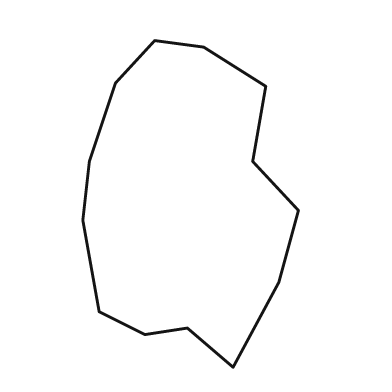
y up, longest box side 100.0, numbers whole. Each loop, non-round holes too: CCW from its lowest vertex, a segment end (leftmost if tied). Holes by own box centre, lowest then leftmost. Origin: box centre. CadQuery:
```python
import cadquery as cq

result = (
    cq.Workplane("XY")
    .moveTo(13.0, -50.0)
    .lineTo(27.0, -24.0)
    .lineTo(33.0, -2.0)
    .lineTo(19.0, 13.0)
    .lineTo(23.0, 36.0)
    .lineTo(4.0, 48.0)
    .lineTo(-11.0, 50.0)
    .lineTo(-23.0, 37.0)
    .lineTo(-31.0, 13.0)
    .lineTo(-33.0, -5.0)
    .lineTo(-28.0, -33.0)
    .lineTo(-14.0, -40.0)
    .lineTo(-1.0, -38.0)
    .close()
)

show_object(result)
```